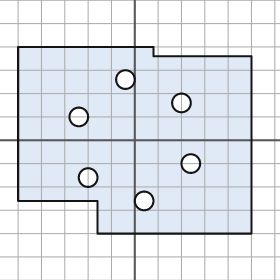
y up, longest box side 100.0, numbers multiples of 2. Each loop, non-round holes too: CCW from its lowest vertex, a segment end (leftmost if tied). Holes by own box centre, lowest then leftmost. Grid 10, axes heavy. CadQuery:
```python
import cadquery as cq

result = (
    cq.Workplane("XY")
    .moveTo(-16.0, -40.0)
    .lineTo(50.0, -40.0)
    .lineTo(50.0, 36.0)
    .lineTo(8.0, 36.0)
    .lineTo(8.0, 40.0)
    .lineTo(-50.0, 40.0)
    .lineTo(-50.0, -26.0)
    .lineTo(-16.0, -26.0)
    .close()
    .moveTo(4.0, -26.0)
    .circle(4.0)
    .moveTo(-20.0, -16.0)
    .circle(4.0)
    .moveTo(24.0, -10.0)
    .circle(4.0)
    .moveTo(-24.0, 10.0)
    .circle(4.0)
    .moveTo(20.0, 16.0)
    .circle(4.0)
    .moveTo(-4.0, 26.0)
    .circle(4.0)
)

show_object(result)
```